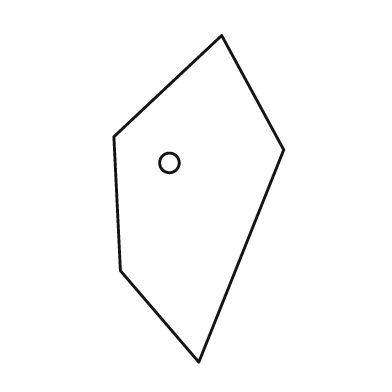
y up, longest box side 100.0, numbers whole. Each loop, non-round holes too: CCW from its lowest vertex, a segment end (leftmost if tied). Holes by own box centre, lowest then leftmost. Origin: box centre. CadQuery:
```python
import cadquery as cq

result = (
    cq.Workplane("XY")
    .moveTo(0.0, -50.0)
    .lineTo(26.0, 15.0)
    .lineTo(7.0, 50.0)
    .lineTo(-26.0, 19.0)
    .lineTo(-24.0, -22.0)
    .close()
    .moveTo(-9.0, 11.0)
    .circle(3.0)
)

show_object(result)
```